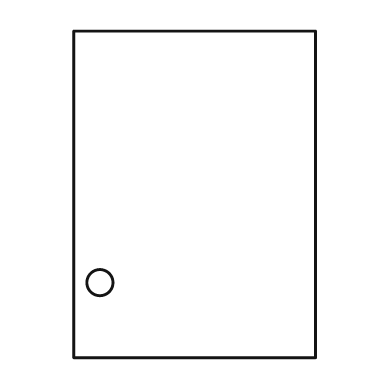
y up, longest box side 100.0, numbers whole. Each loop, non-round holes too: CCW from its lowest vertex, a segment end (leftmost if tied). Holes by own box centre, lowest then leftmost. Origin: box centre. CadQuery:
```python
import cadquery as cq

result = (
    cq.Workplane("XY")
    .moveTo(-37.0, -50.0)
    .lineTo(37.0, -50.0)
    .lineTo(37.0, 50.0)
    .lineTo(-37.0, 50.0)
    .close()
    .moveTo(-29.0, -27.0)
    .circle(4.0)
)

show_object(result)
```